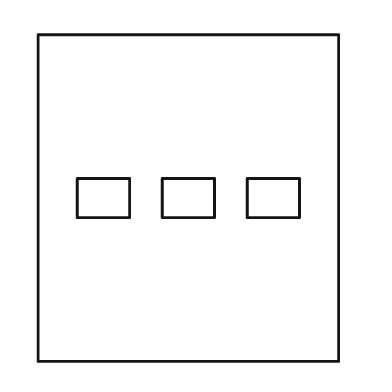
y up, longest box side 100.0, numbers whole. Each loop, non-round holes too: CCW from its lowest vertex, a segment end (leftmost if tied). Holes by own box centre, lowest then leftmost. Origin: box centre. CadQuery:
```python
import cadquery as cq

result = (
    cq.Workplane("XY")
    .moveTo(-46.0, -50.0)
    .lineTo(46.0, -50.0)
    .lineTo(46.0, 50.0)
    .lineTo(-46.0, 50.0)
    .close()
    .moveTo(-34.0, -6.0)
    .lineTo(-18.0, -6.0)
    .lineTo(-18.0, 6.0)
    .lineTo(-34.0, 6.0)
    .close()
    .moveTo(-8.0, -6.0)
    .lineTo(8.0, -6.0)
    .lineTo(8.0, 6.0)
    .lineTo(-8.0, 6.0)
    .close()
    .moveTo(18.0, -6.0)
    .lineTo(34.0, -6.0)
    .lineTo(34.0, 6.0)
    .lineTo(18.0, 6.0)
    .close()
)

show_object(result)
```